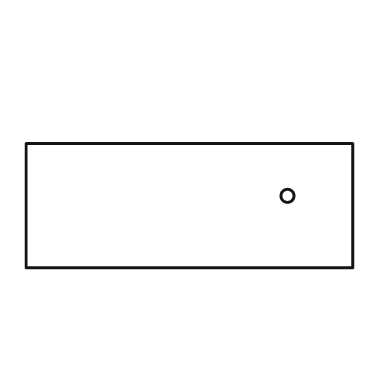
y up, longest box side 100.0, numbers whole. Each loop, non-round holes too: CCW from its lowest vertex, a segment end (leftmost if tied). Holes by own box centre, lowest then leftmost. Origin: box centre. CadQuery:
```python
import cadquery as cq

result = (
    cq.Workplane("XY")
    .moveTo(-50.0, -19.0)
    .lineTo(50.0, -19.0)
    .lineTo(50.0, 19.0)
    .lineTo(-50.0, 19.0)
    .close()
    .moveTo(30.0, 3.0)
    .circle(2.0)
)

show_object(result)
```